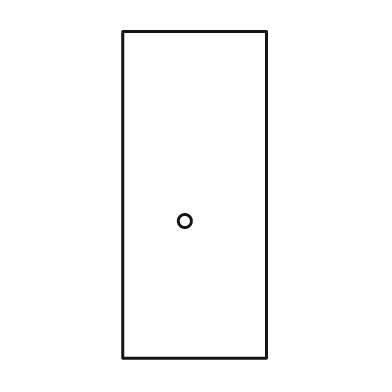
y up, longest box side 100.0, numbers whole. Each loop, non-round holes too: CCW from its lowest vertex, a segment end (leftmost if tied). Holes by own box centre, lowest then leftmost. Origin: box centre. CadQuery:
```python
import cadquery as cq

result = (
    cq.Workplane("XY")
    .moveTo(-22.0, -50.0)
    .lineTo(22.0, -50.0)
    .lineTo(22.0, 50.0)
    .lineTo(-22.0, 50.0)
    .close()
    .moveTo(-3.0, -8.0)
    .circle(2.0)
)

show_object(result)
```